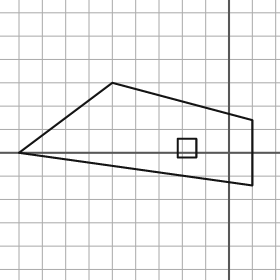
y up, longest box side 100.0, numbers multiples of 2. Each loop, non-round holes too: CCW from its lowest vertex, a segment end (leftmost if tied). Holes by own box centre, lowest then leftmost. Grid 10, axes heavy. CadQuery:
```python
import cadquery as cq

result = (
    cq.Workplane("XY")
    .moveTo(10.0, -14.0)
    .lineTo(10.0, 14.0)
    .lineTo(-50.0, 30.0)
    .lineTo(-90.0, 0.0)
    .close()
    .moveTo(-22.0, -2.0)
    .lineTo(-14.0, -2.0)
    .lineTo(-14.0, 6.0)
    .lineTo(-22.0, 6.0)
    .close()
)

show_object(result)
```